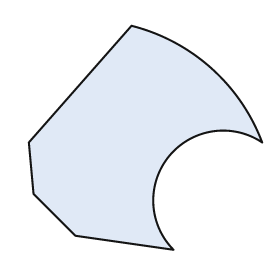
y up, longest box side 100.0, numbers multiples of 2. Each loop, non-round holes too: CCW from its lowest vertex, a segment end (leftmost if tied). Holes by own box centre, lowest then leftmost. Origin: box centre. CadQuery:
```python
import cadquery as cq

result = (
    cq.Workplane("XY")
    .moveTo(12.0, -48.0)
    .threePointArc((10.0, -8.0), (50.0, -2.0))
    .threePointArc((28.0, 30.0), (-6.0, 48.0))
    .lineTo(-50.0, -2.0)
    .lineTo(-48.0, -24.0)
    .lineTo(-30.0, -42.0)
    .close()
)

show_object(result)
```